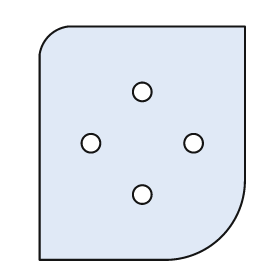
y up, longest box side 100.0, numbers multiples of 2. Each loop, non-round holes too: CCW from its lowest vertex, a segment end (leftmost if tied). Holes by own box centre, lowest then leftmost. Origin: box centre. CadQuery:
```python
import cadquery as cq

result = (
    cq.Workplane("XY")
    .moveTo(-44.0, -50.0)
    .lineTo(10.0, -50.0)
    .threePointArc((34.0, -40.0), (44.0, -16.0))
    .lineTo(44.0, 50.0)
    .lineTo(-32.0, 50.0)
    .threePointArc((-40.0, 46.0), (-44.0, 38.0))
    .close()
    .moveTo(0.0, -22.0)
    .circle(4.0)
    .moveTo(-22.0, 0.0)
    .circle(4.0)
    .moveTo(22.0, 0.0)
    .circle(4.0)
    .moveTo(0.0, 22.0)
    .circle(4.0)
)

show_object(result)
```